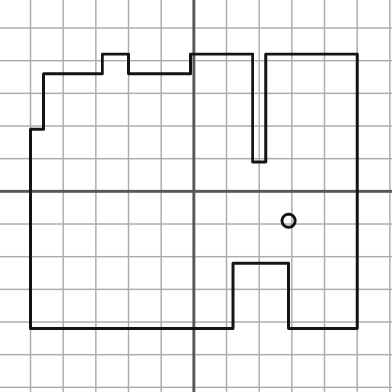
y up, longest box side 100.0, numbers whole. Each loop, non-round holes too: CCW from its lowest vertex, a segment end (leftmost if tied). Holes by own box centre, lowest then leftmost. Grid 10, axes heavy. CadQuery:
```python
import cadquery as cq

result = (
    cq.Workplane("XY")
    .moveTo(-50.0, -42.0)
    .lineTo(12.0, -42.0)
    .lineTo(12.0, -22.0)
    .lineTo(29.0, -22.0)
    .lineTo(29.0, -42.0)
    .lineTo(50.0, -42.0)
    .lineTo(50.0, 42.0)
    .lineTo(22.0, 42.0)
    .lineTo(22.0, 9.0)
    .lineTo(18.0, 9.0)
    .lineTo(18.0, 42.0)
    .lineTo(-1.0, 42.0)
    .lineTo(-1.0, 36.0)
    .lineTo(-20.0, 36.0)
    .lineTo(-20.0, 42.0)
    .lineTo(-28.0, 42.0)
    .lineTo(-28.0, 36.0)
    .lineTo(-46.0, 36.0)
    .lineTo(-46.0, 19.0)
    .lineTo(-50.0, 19.0)
    .close()
    .moveTo(29.0, -9.0)
    .circle(2.0)
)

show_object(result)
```